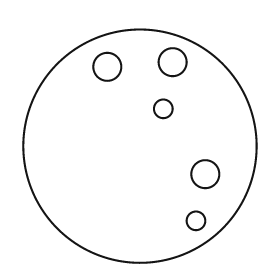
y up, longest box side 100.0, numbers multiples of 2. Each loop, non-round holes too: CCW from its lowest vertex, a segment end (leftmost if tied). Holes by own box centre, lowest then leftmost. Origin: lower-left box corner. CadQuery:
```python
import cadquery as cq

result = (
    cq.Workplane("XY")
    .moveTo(50.0, 50.0)
    .circle(50.0)
    .moveTo(74.0, 18.0)
    .circle(4.0)
    .moveTo(78.0, 38.0)
    .circle(6.0)
    .moveTo(60.0, 66.0)
    .circle(4.0)
    .moveTo(36.0, 84.0)
    .circle(6.0)
    .moveTo(64.0, 86.0)
    .circle(6.0)
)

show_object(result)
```